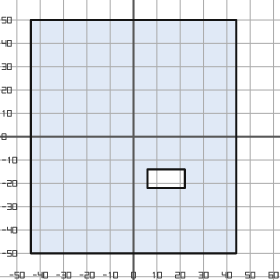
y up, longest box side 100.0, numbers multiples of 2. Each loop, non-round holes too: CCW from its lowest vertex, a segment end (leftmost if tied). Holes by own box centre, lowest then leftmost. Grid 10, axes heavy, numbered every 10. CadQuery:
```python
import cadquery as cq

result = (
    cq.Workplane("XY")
    .moveTo(-44.0, -50.0)
    .lineTo(44.0, -50.0)
    .lineTo(44.0, 50.0)
    .lineTo(-44.0, 50.0)
    .close()
    .moveTo(6.0, -22.0)
    .lineTo(22.0, -22.0)
    .lineTo(22.0, -14.0)
    .lineTo(6.0, -14.0)
    .close()
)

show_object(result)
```